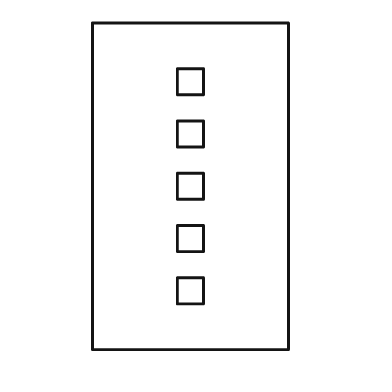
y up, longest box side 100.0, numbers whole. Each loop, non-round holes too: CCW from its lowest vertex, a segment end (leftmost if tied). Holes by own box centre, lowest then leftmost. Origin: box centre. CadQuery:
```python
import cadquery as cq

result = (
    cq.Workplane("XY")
    .moveTo(-30.0, -50.0)
    .lineTo(30.0, -50.0)
    .lineTo(30.0, 50.0)
    .lineTo(-30.0, 50.0)
    .close()
    .moveTo(-4.0, -36.0)
    .lineTo(4.0, -36.0)
    .lineTo(4.0, -28.0)
    .lineTo(-4.0, -28.0)
    .close()
    .moveTo(-4.0, -20.0)
    .lineTo(4.0, -20.0)
    .lineTo(4.0, -12.0)
    .lineTo(-4.0, -12.0)
    .close()
    .moveTo(-4.0, -4.0)
    .lineTo(4.0, -4.0)
    .lineTo(4.0, 4.0)
    .lineTo(-4.0, 4.0)
    .close()
    .moveTo(-4.0, 12.0)
    .lineTo(4.0, 12.0)
    .lineTo(4.0, 20.0)
    .lineTo(-4.0, 20.0)
    .close()
    .moveTo(-4.0, 28.0)
    .lineTo(4.0, 28.0)
    .lineTo(4.0, 36.0)
    .lineTo(-4.0, 36.0)
    .close()
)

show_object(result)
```